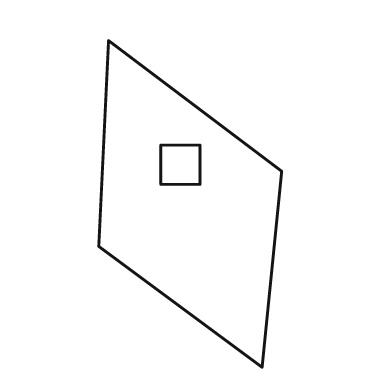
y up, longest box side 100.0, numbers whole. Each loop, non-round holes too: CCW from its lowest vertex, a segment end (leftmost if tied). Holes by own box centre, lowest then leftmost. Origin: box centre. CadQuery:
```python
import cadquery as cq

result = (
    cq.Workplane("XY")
    .moveTo(22.0, -50.0)
    .lineTo(28.0, 10.0)
    .lineTo(-25.0, 50.0)
    .lineTo(-28.0, -13.0)
    .close()
    .moveTo(-9.0, 6.0)
    .lineTo(3.0, 6.0)
    .lineTo(3.0, 18.0)
    .lineTo(-9.0, 18.0)
    .close()
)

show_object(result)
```